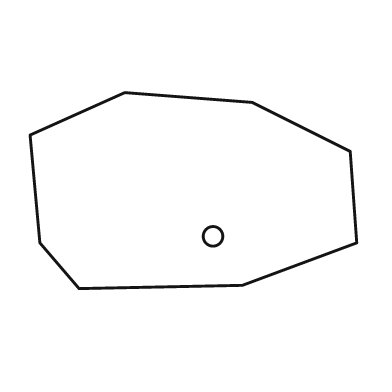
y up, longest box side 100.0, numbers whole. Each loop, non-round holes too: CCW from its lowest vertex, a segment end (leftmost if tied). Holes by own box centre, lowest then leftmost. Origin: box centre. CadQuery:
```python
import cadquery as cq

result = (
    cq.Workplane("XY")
    .moveTo(-35.0, -30.0)
    .lineTo(15.0, -29.0)
    .lineTo(50.0, -16.0)
    .lineTo(48.0, 12.0)
    .lineTo(18.0, 27.0)
    .lineTo(-21.0, 30.0)
    .lineTo(-50.0, 17.0)
    .lineTo(-47.0, -16.0)
    .close()
    .moveTo(6.0, -14.0)
    .circle(3.0)
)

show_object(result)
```